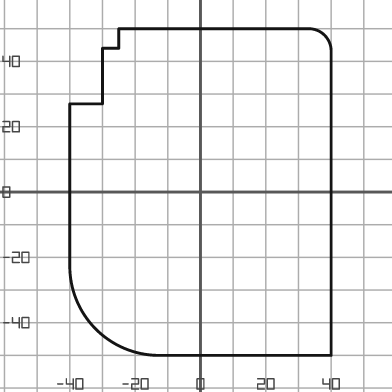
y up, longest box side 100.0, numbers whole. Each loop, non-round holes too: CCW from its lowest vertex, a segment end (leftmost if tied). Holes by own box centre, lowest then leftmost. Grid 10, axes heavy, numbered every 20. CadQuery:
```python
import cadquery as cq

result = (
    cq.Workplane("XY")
    .moveTo(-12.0, -50.0)
    .lineTo(40.0, -50.0)
    .lineTo(40.0, 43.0)
    .threePointArc((38.0, 48.0), (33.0, 50.0))
    .lineTo(-25.0, 50.0)
    .lineTo(-25.0, 44.0)
    .lineTo(-30.0, 44.0)
    .lineTo(-30.0, 27.0)
    .lineTo(-40.0, 27.0)
    .lineTo(-40.0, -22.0)
    .threePointArc((-32.0, -42.0), (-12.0, -50.0))
    .close()
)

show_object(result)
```